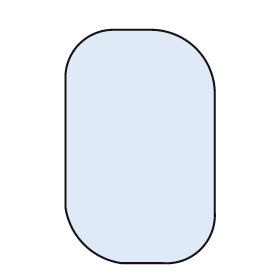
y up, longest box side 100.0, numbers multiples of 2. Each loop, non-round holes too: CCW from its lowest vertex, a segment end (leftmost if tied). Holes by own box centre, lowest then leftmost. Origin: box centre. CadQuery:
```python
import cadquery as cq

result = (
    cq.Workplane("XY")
    .moveTo(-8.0, -50.0)
    .lineTo(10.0, -50.0)
    .threePointArc((26.0, -44.0), (32.0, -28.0))
    .lineTo(32.0, 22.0)
    .threePointArc((24.0, 42.0), (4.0, 50.0))
    .lineTo(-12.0, 50.0)
    .threePointArc((-26.0, 44.0), (-32.0, 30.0))
    .lineTo(-32.0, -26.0)
    .threePointArc((-24.0, -42.0), (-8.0, -50.0))
    .close()
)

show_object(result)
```